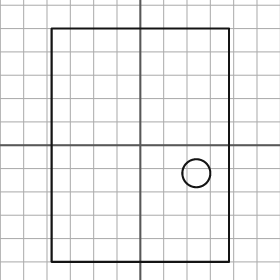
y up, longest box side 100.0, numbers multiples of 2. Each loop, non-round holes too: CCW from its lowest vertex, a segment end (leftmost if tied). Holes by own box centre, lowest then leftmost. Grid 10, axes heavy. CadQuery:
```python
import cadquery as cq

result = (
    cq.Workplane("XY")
    .moveTo(-38.0, -50.0)
    .lineTo(38.0, -50.0)
    .lineTo(38.0, 50.0)
    .lineTo(-38.0, 50.0)
    .close()
    .moveTo(24.0, -12.0)
    .circle(6.0)
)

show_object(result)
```